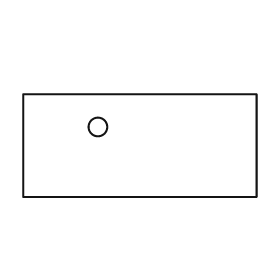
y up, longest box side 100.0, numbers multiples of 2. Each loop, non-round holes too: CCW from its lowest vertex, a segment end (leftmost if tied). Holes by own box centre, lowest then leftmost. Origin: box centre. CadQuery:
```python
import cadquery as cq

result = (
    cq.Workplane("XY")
    .moveTo(-50.0, -22.0)
    .lineTo(50.0, -22.0)
    .lineTo(50.0, 22.0)
    .lineTo(-50.0, 22.0)
    .close()
    .moveTo(-18.0, 8.0)
    .circle(4.0)
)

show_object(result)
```